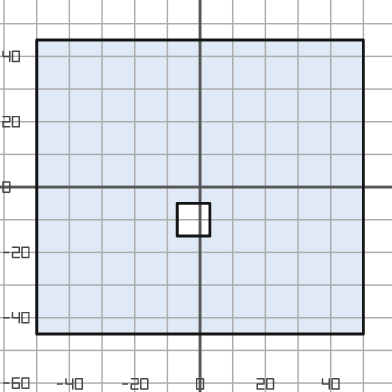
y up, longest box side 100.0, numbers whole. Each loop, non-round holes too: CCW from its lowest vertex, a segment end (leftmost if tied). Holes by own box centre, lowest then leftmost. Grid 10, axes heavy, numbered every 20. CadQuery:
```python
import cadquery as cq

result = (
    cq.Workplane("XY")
    .moveTo(-50.0, -45.0)
    .lineTo(50.0, -45.0)
    .lineTo(50.0, 45.0)
    .lineTo(-50.0, 45.0)
    .close()
    .moveTo(-7.0, -15.0)
    .lineTo(3.0, -15.0)
    .lineTo(3.0, -5.0)
    .lineTo(-7.0, -5.0)
    .close()
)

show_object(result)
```